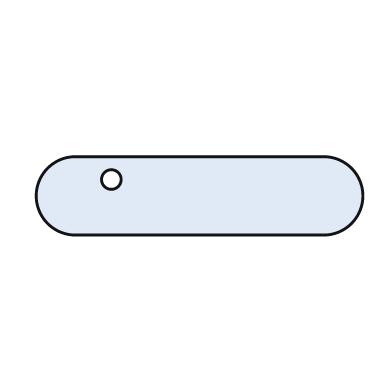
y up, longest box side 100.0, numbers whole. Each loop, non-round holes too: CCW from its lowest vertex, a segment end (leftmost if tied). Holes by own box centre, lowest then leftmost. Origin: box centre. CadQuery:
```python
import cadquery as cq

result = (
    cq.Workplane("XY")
    .moveTo(-38.0, -12.0)
    .lineTo(38.0, -12.0)
    .threePointArc((50.0, 0.0), (38.0, 12.0))
    .lineTo(-38.0, 12.0)
    .threePointArc((-50.0, 0.0), (-38.0, -12.0))
    .close()
    .moveTo(-27.0, 5.0)
    .circle(3.0)
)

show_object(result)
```